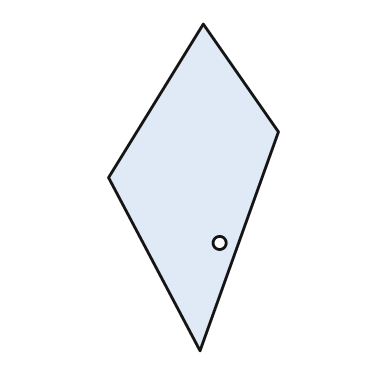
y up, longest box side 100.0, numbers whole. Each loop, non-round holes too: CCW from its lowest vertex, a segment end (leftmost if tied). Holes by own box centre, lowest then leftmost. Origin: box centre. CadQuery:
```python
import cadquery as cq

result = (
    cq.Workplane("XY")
    .moveTo(2.0, -50.0)
    .lineTo(26.0, 17.0)
    .lineTo(3.0, 50.0)
    .lineTo(-26.0, 3.0)
    .close()
    .moveTo(8.0, -17.0)
    .circle(2.0)
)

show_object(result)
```